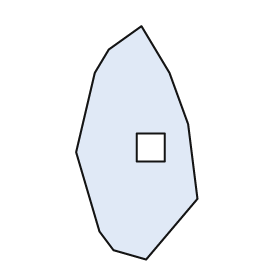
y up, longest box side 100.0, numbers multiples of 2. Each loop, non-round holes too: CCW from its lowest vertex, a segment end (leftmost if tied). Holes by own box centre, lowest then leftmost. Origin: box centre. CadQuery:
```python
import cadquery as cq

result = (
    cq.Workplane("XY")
    .moveTo(4.0, -50.0)
    .lineTo(26.0, -24.0)
    .lineTo(22.0, 8.0)
    .lineTo(14.0, 30.0)
    .lineTo(2.0, 50.0)
    .lineTo(-12.0, 40.0)
    .lineTo(-18.0, 30.0)
    .lineTo(-26.0, -4.0)
    .lineTo(-16.0, -38.0)
    .lineTo(-10.0, -46.0)
    .close()
    .moveTo(0.0, -8.0)
    .lineTo(12.0, -8.0)
    .lineTo(12.0, 4.0)
    .lineTo(0.0, 4.0)
    .close()
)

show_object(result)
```